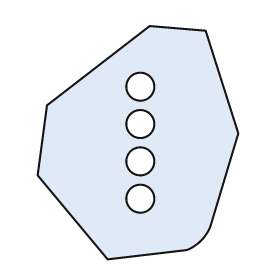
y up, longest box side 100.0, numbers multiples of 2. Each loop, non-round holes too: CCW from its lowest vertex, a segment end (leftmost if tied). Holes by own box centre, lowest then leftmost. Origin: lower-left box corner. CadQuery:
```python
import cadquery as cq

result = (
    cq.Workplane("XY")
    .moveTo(30.0, 0.0)
    .lineTo(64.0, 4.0)
    .threePointArc((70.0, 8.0), (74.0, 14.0))
    .lineTo(86.0, 54.0)
    .lineTo(72.0, 98.0)
    .lineTo(48.0, 100.0)
    .lineTo(4.0, 66.0)
    .lineTo(0.0, 36.0)
    .close()
    .moveTo(44.0, 26.0)
    .circle(6.0)
    .moveTo(44.0, 42.0)
    .circle(6.0)
    .moveTo(44.0, 58.0)
    .circle(6.0)
    .moveTo(44.0, 74.0)
    .circle(6.0)
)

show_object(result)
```